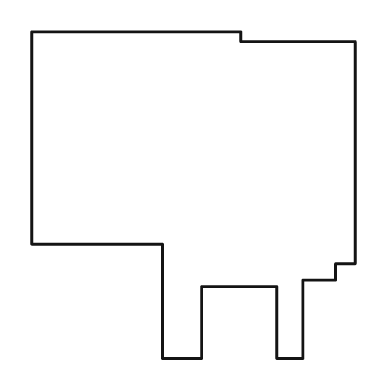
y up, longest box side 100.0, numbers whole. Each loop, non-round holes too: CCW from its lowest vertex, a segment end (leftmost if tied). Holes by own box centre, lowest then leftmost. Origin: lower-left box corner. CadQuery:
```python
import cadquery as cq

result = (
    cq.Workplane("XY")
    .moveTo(40.0, 0.0)
    .lineTo(52.0, 0.0)
    .lineTo(52.0, 22.0)
    .lineTo(75.0, 22.0)
    .lineTo(75.0, 0.0)
    .lineTo(83.0, 0.0)
    .lineTo(83.0, 24.0)
    .lineTo(93.0, 24.0)
    .lineTo(93.0, 29.0)
    .lineTo(99.0, 29.0)
    .lineTo(99.0, 97.0)
    .lineTo(64.0, 97.0)
    .lineTo(64.0, 100.0)
    .lineTo(0.0, 100.0)
    .lineTo(0.0, 35.0)
    .lineTo(40.0, 35.0)
    .close()
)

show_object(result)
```